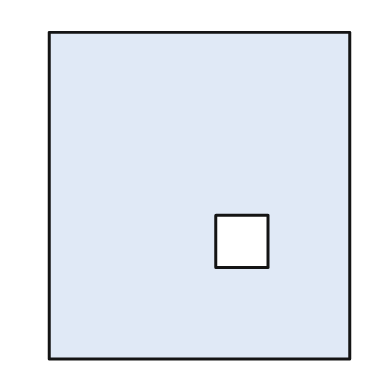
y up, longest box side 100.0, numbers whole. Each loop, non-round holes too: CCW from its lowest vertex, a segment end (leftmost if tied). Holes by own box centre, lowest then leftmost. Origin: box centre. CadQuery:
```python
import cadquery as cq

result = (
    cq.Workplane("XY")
    .moveTo(-46.0, -50.0)
    .lineTo(46.0, -50.0)
    .lineTo(46.0, 50.0)
    .lineTo(-46.0, 50.0)
    .close()
    .moveTo(5.0, -22.0)
    .lineTo(21.0, -22.0)
    .lineTo(21.0, -6.0)
    .lineTo(5.0, -6.0)
    .close()
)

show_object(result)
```